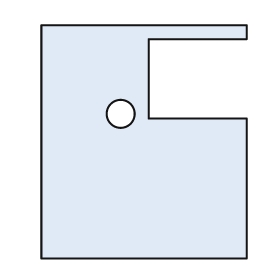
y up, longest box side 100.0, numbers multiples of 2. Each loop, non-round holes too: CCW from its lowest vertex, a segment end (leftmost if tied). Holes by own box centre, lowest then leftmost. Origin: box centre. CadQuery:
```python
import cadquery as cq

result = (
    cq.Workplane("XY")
    .moveTo(-44.0, -50.0)
    .lineTo(44.0, -50.0)
    .lineTo(44.0, 10.0)
    .lineTo(2.0, 10.0)
    .lineTo(2.0, 44.0)
    .lineTo(44.0, 44.0)
    .lineTo(44.0, 50.0)
    .lineTo(-44.0, 50.0)
    .close()
    .moveTo(-10.0, 12.0)
    .circle(6.0)
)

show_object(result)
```